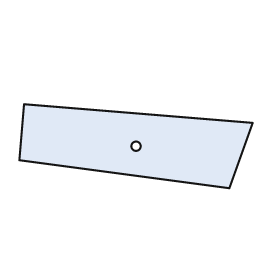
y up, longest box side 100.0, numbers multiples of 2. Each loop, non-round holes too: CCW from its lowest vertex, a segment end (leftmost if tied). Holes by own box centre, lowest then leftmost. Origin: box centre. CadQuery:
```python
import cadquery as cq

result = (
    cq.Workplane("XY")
    .moveTo(40.0, -18.0)
    .lineTo(50.0, 10.0)
    .lineTo(-48.0, 18.0)
    .lineTo(-50.0, -6.0)
    .close()
    .moveTo(0.0, 0.0)
    .circle(2.0)
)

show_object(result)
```